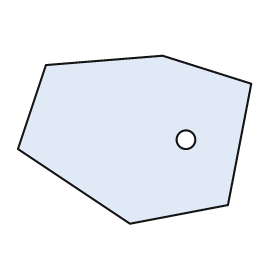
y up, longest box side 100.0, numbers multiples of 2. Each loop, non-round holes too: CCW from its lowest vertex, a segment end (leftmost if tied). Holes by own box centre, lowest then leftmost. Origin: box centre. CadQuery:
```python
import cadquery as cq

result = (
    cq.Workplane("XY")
    .moveTo(-2.0, -36.0)
    .lineTo(40.0, -28.0)
    .lineTo(50.0, 24.0)
    .lineTo(12.0, 36.0)
    .lineTo(-38.0, 32.0)
    .lineTo(-50.0, -4.0)
    .close()
    .moveTo(22.0, 0.0)
    .circle(4.0)
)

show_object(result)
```